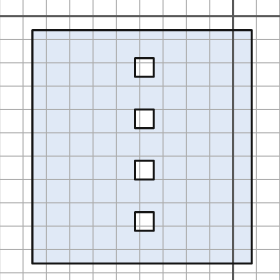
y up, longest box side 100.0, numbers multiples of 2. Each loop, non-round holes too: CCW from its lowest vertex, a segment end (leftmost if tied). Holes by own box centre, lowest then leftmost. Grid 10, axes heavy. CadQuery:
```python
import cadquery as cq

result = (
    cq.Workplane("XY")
    .moveTo(-86.0, -106.0)
    .lineTo(8.0, -106.0)
    .lineTo(8.0, -6.0)
    .lineTo(-86.0, -6.0)
    .close()
    .moveTo(-42.0, -92.0)
    .lineTo(-34.0, -92.0)
    .lineTo(-34.0, -84.0)
    .lineTo(-42.0, -84.0)
    .close()
    .moveTo(-42.0, -70.0)
    .lineTo(-34.0, -70.0)
    .lineTo(-34.0, -62.0)
    .lineTo(-42.0, -62.0)
    .close()
    .moveTo(-42.0, -48.0)
    .lineTo(-34.0, -48.0)
    .lineTo(-34.0, -40.0)
    .lineTo(-42.0, -40.0)
    .close()
    .moveTo(-42.0, -26.0)
    .lineTo(-34.0, -26.0)
    .lineTo(-34.0, -18.0)
    .lineTo(-42.0, -18.0)
    .close()
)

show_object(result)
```